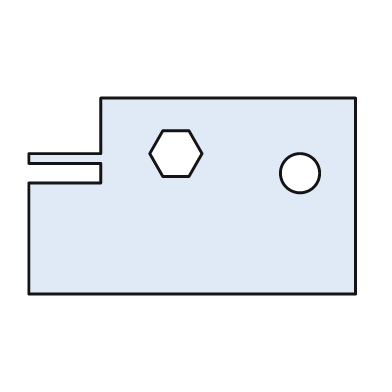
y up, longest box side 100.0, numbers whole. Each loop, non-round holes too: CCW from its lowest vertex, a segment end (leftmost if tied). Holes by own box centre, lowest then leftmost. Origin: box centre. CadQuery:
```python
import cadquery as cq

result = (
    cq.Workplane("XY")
    .moveTo(-50.0, -30.0)
    .lineTo(50.0, -30.0)
    .lineTo(50.0, 30.0)
    .lineTo(-28.0, 30.0)
    .lineTo(-28.0, 13.0)
    .lineTo(-50.0, 13.0)
    .lineTo(-50.0, 10.0)
    .lineTo(-28.0, 10.0)
    .lineTo(-28.0, 4.0)
    .lineTo(-50.0, 4.0)
    .close()
    .moveTo(33.0, 7.0)
    .circle(6.0)
    .moveTo(-9.0, 6.0)
    .lineTo(-1.0, 6.0)
    .lineTo(3.0, 13.0)
    .lineTo(-1.0, 20.0)
    .lineTo(-9.0, 20.0)
    .lineTo(-13.0, 13.0)
    .close()
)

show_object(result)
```